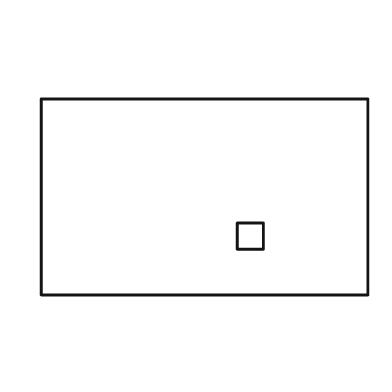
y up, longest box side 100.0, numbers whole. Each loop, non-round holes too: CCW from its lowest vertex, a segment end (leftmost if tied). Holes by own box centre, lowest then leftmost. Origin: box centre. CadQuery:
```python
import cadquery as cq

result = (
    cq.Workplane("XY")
    .moveTo(-50.0, -30.0)
    .lineTo(50.0, -30.0)
    .lineTo(50.0, 30.0)
    .lineTo(-50.0, 30.0)
    .close()
    .moveTo(10.0, -16.0)
    .lineTo(18.0, -16.0)
    .lineTo(18.0, -8.0)
    .lineTo(10.0, -8.0)
    .close()
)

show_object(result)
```